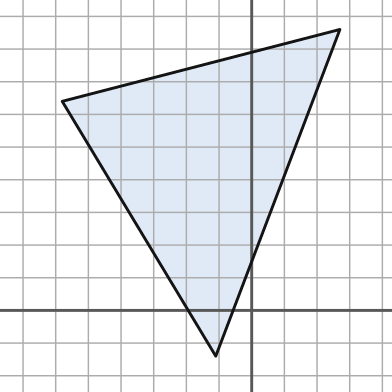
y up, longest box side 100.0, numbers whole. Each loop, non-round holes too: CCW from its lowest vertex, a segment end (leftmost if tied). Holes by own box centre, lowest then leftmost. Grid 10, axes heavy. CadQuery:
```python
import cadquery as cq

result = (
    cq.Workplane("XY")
    .moveTo(-11.0, -14.0)
    .lineTo(27.0, 86.0)
    .lineTo(-58.0, 64.0)
    .close()
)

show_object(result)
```